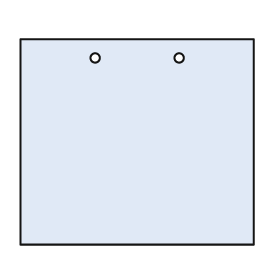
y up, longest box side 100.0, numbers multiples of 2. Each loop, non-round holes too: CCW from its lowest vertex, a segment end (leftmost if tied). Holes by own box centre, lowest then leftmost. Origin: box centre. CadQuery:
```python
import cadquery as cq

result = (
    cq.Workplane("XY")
    .moveTo(-50.0, -44.0)
    .lineTo(50.0, -44.0)
    .lineTo(50.0, 44.0)
    .lineTo(-50.0, 44.0)
    .close()
    .moveTo(-18.0, 36.0)
    .circle(2.0)
    .moveTo(18.0, 36.0)
    .circle(2.0)
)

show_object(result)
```